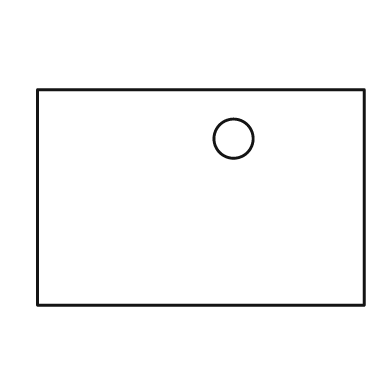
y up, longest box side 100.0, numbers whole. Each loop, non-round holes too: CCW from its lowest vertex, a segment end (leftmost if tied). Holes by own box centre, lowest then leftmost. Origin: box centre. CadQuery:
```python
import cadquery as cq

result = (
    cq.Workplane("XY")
    .moveTo(-50.0, -33.0)
    .lineTo(50.0, -33.0)
    .lineTo(50.0, 33.0)
    .lineTo(-50.0, 33.0)
    .close()
    .moveTo(10.0, 18.0)
    .circle(6.0)
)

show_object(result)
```